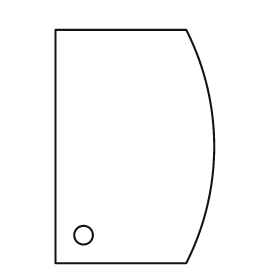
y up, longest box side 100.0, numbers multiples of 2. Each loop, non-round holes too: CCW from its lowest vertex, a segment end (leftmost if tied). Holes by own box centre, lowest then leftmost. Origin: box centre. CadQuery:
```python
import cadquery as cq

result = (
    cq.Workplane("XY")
    .moveTo(-34.0, -50.0)
    .lineTo(22.0, -50.0)
    .threePointArc((34.0, 0.0), (22.0, 50.0))
    .lineTo(-34.0, 50.0)
    .close()
    .moveTo(-22.0, -38.0)
    .circle(4.0)
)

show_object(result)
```